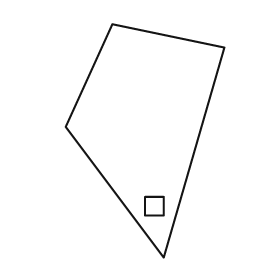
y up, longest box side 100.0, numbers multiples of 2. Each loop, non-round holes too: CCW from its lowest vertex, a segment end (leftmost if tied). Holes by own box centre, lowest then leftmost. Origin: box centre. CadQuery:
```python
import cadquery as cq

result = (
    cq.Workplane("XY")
    .moveTo(8.0, -50.0)
    .lineTo(34.0, 40.0)
    .lineTo(-14.0, 50.0)
    .lineTo(-34.0, 6.0)
    .close()
    .moveTo(0.0, -32.0)
    .lineTo(8.0, -32.0)
    .lineTo(8.0, -24.0)
    .lineTo(0.0, -24.0)
    .close()
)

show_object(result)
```